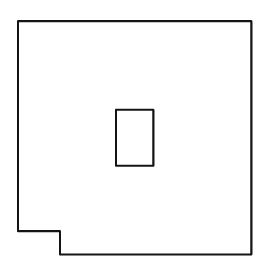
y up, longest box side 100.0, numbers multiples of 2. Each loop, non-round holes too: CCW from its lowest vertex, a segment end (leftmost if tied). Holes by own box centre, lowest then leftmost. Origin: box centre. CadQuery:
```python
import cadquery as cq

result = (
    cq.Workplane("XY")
    .moveTo(-32.0, -50.0)
    .lineTo(50.0, -50.0)
    .lineTo(50.0, 50.0)
    .lineTo(-50.0, 50.0)
    .lineTo(-50.0, -40.0)
    .lineTo(-32.0, -40.0)
    .close()
    .moveTo(-8.0, -12.0)
    .lineTo(8.0, -12.0)
    .lineTo(8.0, 12.0)
    .lineTo(-8.0, 12.0)
    .close()
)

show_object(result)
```